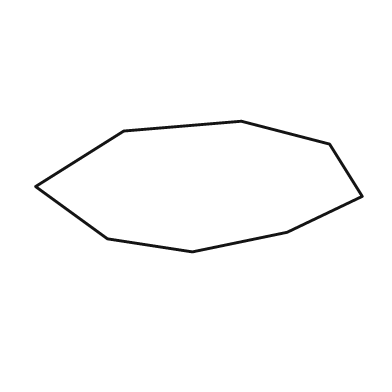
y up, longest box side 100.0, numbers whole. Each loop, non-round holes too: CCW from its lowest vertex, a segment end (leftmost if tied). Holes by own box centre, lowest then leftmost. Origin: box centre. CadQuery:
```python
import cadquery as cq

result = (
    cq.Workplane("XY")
    .moveTo(-2.0, -20.0)
    .lineTo(27.0, -14.0)
    .lineTo(50.0, -3.0)
    .lineTo(40.0, 13.0)
    .lineTo(13.0, 20.0)
    .lineTo(-23.0, 17.0)
    .lineTo(-50.0, 0.0)
    .lineTo(-28.0, -16.0)
    .close()
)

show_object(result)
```